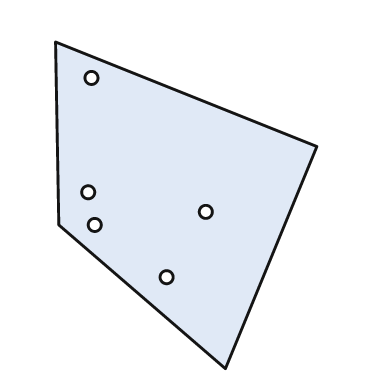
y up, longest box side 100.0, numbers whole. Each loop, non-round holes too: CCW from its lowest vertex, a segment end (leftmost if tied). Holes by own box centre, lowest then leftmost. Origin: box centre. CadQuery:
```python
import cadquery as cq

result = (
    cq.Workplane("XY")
    .moveTo(12.0, -50.0)
    .lineTo(40.0, 18.0)
    .lineTo(-40.0, 50.0)
    .lineTo(-39.0, -6.0)
    .close()
    .moveTo(-6.0, -22.0)
    .circle(2.0)
    .moveTo(-28.0, -6.0)
    .circle(2.0)
    .moveTo(6.0, -2.0)
    .circle(2.0)
    .moveTo(-30.0, 4.0)
    .circle(2.0)
    .moveTo(-29.0, 39.0)
    .circle(2.0)
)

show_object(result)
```